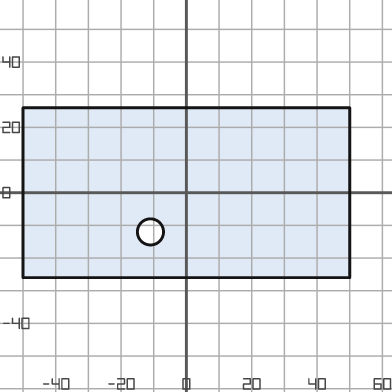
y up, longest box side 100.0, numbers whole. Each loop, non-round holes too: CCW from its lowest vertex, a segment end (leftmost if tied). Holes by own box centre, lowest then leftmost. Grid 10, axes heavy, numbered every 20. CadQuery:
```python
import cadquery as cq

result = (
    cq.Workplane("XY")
    .moveTo(-50.0, -26.0)
    .lineTo(50.0, -26.0)
    .lineTo(50.0, 26.0)
    .lineTo(-50.0, 26.0)
    .close()
    .moveTo(-11.0, -12.0)
    .circle(4.0)
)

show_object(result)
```